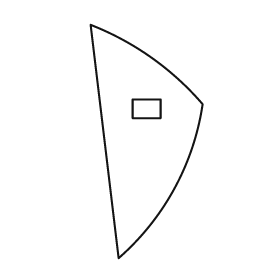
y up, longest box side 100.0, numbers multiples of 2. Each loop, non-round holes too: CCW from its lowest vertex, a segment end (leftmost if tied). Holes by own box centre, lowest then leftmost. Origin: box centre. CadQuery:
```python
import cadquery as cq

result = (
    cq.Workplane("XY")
    .moveTo(-12.0, -50.0)
    .threePointArc((12.0, -20.0), (24.0, 16.0))
    .threePointArc((2.0, 36.0), (-24.0, 50.0))
    .close()
    .moveTo(-6.0, 10.0)
    .lineTo(6.0, 10.0)
    .lineTo(6.0, 18.0)
    .lineTo(-6.0, 18.0)
    .close()
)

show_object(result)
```